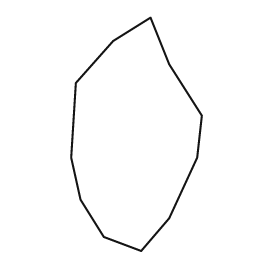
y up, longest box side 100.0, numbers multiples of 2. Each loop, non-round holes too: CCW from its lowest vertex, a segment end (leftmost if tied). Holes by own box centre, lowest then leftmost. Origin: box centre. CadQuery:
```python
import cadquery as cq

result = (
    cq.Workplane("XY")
    .moveTo(2.0, -50.0)
    .lineTo(14.0, -36.0)
    .lineTo(26.0, -10.0)
    .lineTo(28.0, 8.0)
    .lineTo(14.0, 30.0)
    .lineTo(6.0, 50.0)
    .lineTo(-10.0, 40.0)
    .lineTo(-26.0, 22.0)
    .lineTo(-28.0, -10.0)
    .lineTo(-24.0, -28.0)
    .lineTo(-14.0, -44.0)
    .close()
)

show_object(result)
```